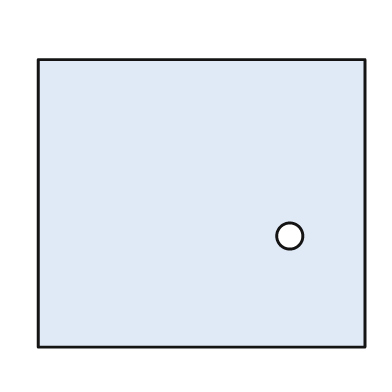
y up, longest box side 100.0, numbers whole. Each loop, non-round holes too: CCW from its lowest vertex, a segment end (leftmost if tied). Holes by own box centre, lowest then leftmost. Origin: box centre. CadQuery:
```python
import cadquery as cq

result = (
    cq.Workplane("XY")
    .moveTo(-50.0, -44.0)
    .lineTo(50.0, -44.0)
    .lineTo(50.0, 44.0)
    .lineTo(-50.0, 44.0)
    .close()
    .moveTo(27.0, -10.0)
    .circle(4.0)
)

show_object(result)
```